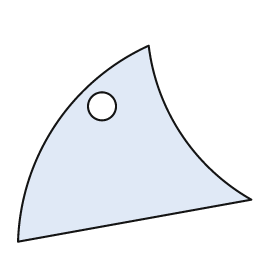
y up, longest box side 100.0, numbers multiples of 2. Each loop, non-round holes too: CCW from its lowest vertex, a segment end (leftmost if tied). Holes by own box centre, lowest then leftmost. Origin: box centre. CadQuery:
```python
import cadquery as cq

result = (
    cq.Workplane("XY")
    .moveTo(-50.0, -42.0)
    .lineTo(50.0, -24.0)
    .threePointArc((20.0, 4.0), (6.0, 42.0))
    .threePointArc((-34.0, 8.0), (-50.0, -42.0))
    .close()
    .moveTo(-14.0, 16.0)
    .circle(6.0)
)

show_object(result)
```